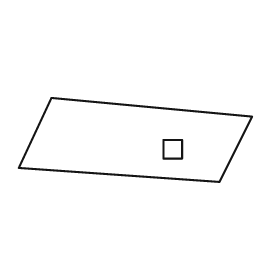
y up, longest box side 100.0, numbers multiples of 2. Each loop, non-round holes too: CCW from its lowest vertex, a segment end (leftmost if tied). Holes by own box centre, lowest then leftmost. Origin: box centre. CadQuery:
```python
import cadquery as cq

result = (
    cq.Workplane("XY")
    .moveTo(36.0, -18.0)
    .lineTo(50.0, 10.0)
    .lineTo(-36.0, 18.0)
    .lineTo(-50.0, -12.0)
    .close()
    .moveTo(12.0, -8.0)
    .lineTo(20.0, -8.0)
    .lineTo(20.0, 0.0)
    .lineTo(12.0, 0.0)
    .close()
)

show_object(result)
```